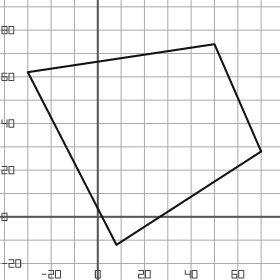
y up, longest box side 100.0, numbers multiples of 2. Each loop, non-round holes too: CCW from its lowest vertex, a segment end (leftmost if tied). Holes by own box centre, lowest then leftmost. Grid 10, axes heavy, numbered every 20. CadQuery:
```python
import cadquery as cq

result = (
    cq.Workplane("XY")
    .moveTo(8.0, -12.0)
    .lineTo(70.0, 28.0)
    .lineTo(50.0, 74.0)
    .lineTo(-30.0, 62.0)
    .close()
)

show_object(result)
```